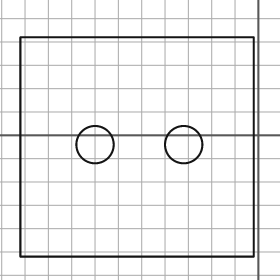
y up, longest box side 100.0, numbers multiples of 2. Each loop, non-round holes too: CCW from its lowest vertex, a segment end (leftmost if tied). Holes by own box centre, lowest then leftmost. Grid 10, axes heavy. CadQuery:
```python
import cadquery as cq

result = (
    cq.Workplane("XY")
    .moveTo(-102.0, -52.0)
    .lineTo(-2.0, -52.0)
    .lineTo(-2.0, 42.0)
    .lineTo(-102.0, 42.0)
    .close()
    .moveTo(-70.0, -4.0)
    .circle(8.0)
    .moveTo(-32.0, -4.0)
    .circle(8.0)
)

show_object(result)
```